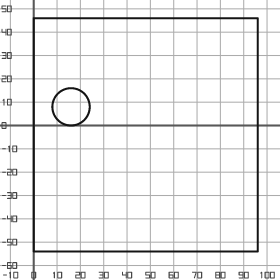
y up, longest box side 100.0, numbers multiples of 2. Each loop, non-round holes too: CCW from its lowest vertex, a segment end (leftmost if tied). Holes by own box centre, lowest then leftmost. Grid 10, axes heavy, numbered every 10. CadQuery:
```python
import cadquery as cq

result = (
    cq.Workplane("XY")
    .moveTo(0.0, -54.0)
    .lineTo(96.0, -54.0)
    .lineTo(96.0, 46.0)
    .lineTo(0.0, 46.0)
    .close()
    .moveTo(16.0, 8.0)
    .circle(8.0)
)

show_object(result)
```